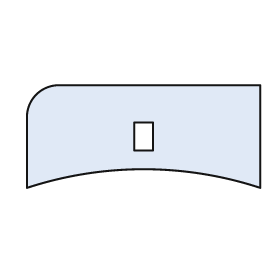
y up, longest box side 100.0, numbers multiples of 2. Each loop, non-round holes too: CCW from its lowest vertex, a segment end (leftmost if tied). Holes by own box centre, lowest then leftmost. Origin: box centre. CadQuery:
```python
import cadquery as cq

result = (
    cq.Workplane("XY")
    .moveTo(-50.0, -22.0)
    .threePointArc((0.0, -14.0), (50.0, -22.0))
    .lineTo(50.0, 22.0)
    .lineTo(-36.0, 22.0)
    .threePointArc((-46.0, 18.0), (-50.0, 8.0))
    .close()
    .moveTo(-4.0, -6.0)
    .lineTo(4.0, -6.0)
    .lineTo(4.0, 6.0)
    .lineTo(-4.0, 6.0)
    .close()
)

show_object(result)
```